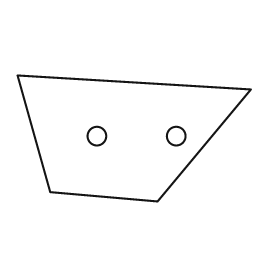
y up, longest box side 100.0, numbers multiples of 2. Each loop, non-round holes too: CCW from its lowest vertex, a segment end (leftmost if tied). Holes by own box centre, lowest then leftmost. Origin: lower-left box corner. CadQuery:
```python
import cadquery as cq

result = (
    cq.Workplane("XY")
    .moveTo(60.0, 0.0)
    .lineTo(100.0, 48.0)
    .lineTo(0.0, 54.0)
    .lineTo(14.0, 4.0)
    .close()
    .moveTo(34.0, 28.0)
    .circle(4.0)
    .moveTo(68.0, 28.0)
    .circle(4.0)
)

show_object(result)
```